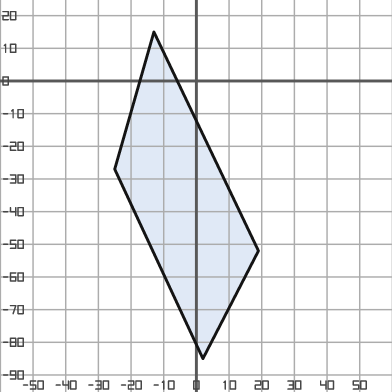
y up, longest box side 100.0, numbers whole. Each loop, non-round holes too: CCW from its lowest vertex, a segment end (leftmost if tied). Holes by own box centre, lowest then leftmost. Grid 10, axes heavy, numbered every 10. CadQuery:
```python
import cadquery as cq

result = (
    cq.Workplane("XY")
    .moveTo(2.0, -85.0)
    .lineTo(19.0, -52.0)
    .lineTo(-13.0, 15.0)
    .lineTo(-25.0, -27.0)
    .close()
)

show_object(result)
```